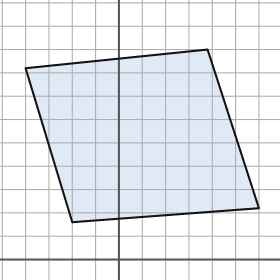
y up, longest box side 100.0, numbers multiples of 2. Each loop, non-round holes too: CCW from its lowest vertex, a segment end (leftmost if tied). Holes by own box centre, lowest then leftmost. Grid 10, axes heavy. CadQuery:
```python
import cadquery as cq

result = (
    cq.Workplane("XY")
    .moveTo(-20.0, 16.0)
    .lineTo(60.0, 22.0)
    .lineTo(38.0, 90.0)
    .lineTo(-40.0, 82.0)
    .close()
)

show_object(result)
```